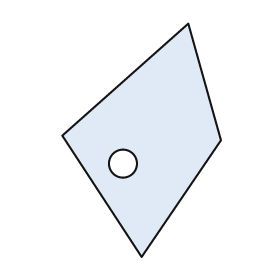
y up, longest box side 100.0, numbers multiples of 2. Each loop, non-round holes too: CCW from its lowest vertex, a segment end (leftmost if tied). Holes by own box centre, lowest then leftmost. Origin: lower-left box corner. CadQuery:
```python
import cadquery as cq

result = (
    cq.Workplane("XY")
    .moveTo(34.0, 0.0)
    .lineTo(68.0, 50.0)
    .lineTo(54.0, 100.0)
    .lineTo(0.0, 52.0)
    .close()
    .moveTo(26.0, 40.0)
    .circle(6.0)
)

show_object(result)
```